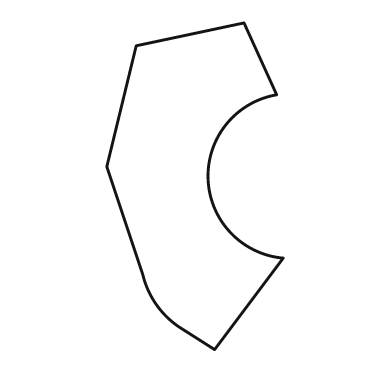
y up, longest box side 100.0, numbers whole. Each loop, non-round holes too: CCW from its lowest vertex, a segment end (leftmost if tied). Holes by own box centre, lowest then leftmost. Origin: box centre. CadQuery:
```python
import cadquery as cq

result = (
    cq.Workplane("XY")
    .moveTo(6.0, -50.0)
    .lineTo(27.0, -22.0)
    .threePointArc((4.0, 2.0), (25.0, 28.0))
    .lineTo(15.0, 50.0)
    .lineTo(-18.0, 43.0)
    .lineTo(-27.0, 6.0)
    .lineTo(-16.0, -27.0)
    .threePointArc((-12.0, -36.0), (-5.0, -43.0))
    .close()
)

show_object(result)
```